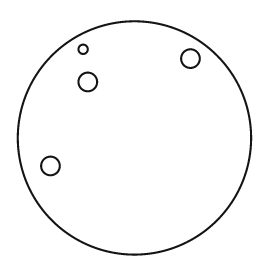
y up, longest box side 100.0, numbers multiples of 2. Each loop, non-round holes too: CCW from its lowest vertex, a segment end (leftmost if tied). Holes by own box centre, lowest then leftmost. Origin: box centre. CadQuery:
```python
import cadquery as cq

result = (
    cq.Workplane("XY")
    .moveTo(0.0, 0.0)
    .circle(50.0)
    .moveTo(-36.0, -12.0)
    .circle(4.0)
    .moveTo(-20.0, 24.0)
    .circle(4.0)
    .moveTo(24.0, 34.0)
    .circle(4.0)
    .moveTo(-22.0, 38.0)
    .circle(2.0)
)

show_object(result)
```